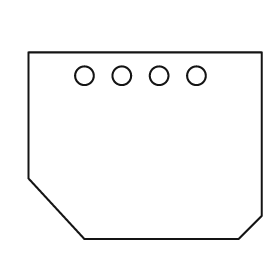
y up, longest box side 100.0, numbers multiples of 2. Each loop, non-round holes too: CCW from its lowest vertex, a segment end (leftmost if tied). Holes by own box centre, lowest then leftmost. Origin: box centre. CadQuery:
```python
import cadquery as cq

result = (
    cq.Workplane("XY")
    .moveTo(-26.0, -40.0)
    .lineTo(40.0, -40.0)
    .lineTo(50.0, -30.0)
    .lineTo(50.0, 40.0)
    .lineTo(-50.0, 40.0)
    .lineTo(-50.0, -14.0)
    .close()
    .moveTo(-26.0, 30.0)
    .circle(4.0)
    .moveTo(-10.0, 30.0)
    .circle(4.0)
    .moveTo(6.0, 30.0)
    .circle(4.0)
    .moveTo(22.0, 30.0)
    .circle(4.0)
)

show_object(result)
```